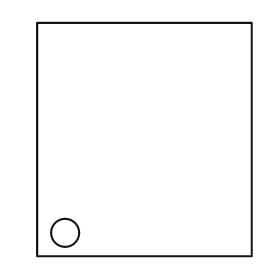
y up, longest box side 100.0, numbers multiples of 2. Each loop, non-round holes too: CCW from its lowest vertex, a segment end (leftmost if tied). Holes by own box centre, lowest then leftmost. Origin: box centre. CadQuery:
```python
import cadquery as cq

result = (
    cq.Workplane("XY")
    .moveTo(-46.0, -50.0)
    .lineTo(46.0, -50.0)
    .lineTo(46.0, 50.0)
    .lineTo(-46.0, 50.0)
    .close()
    .moveTo(-34.0, -40.0)
    .circle(6.0)
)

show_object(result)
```